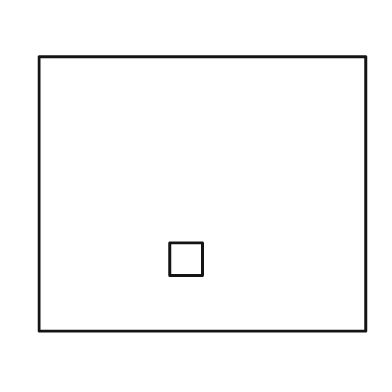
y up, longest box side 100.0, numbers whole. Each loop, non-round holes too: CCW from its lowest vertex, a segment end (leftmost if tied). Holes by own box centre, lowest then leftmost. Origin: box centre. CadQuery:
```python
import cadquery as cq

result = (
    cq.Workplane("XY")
    .moveTo(-50.0, -42.0)
    .lineTo(50.0, -42.0)
    .lineTo(50.0, 42.0)
    .lineTo(-50.0, 42.0)
    .close()
    .moveTo(-10.0, -25.0)
    .lineTo(0.0, -25.0)
    .lineTo(0.0, -15.0)
    .lineTo(-10.0, -15.0)
    .close()
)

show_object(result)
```